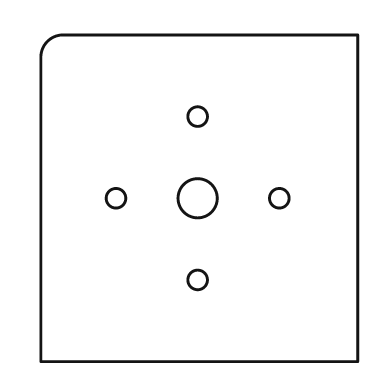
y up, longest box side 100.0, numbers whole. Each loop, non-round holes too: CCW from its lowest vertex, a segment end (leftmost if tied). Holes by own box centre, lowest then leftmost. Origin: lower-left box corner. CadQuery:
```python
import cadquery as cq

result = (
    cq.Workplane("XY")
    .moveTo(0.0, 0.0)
    .lineTo(97.0, 0.0)
    .lineTo(97.0, 100.0)
    .lineTo(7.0, 100.0)
    .threePointArc((2.0, 98.0), (0.0, 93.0))
    .close()
    .moveTo(48.0, 25.0)
    .circle(3.0)
    .moveTo(23.0, 50.0)
    .circle(3.0)
    .moveTo(48.0, 50.0)
    .circle(6.0)
    .moveTo(73.0, 50.0)
    .circle(3.0)
    .moveTo(48.0, 75.0)
    .circle(3.0)
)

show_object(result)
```